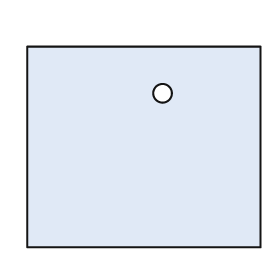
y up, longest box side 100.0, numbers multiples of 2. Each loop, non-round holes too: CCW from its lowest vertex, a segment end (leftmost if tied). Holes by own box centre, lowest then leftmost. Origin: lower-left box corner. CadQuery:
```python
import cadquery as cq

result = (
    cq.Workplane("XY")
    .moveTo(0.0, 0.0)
    .lineTo(100.0, 0.0)
    .lineTo(100.0, 86.0)
    .lineTo(0.0, 86.0)
    .close()
    .moveTo(58.0, 66.0)
    .circle(4.0)
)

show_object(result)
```